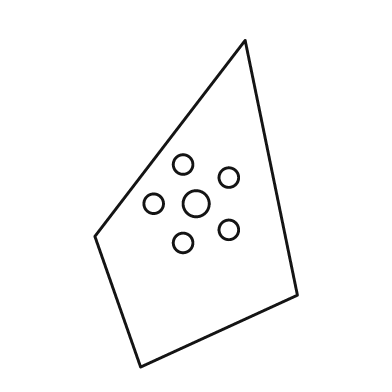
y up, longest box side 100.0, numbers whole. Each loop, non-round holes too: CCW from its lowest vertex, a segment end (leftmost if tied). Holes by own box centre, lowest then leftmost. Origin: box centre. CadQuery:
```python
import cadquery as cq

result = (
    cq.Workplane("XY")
    .moveTo(-17.0, -50.0)
    .lineTo(31.0, -28.0)
    .lineTo(15.0, 50.0)
    .lineTo(-31.0, -10.0)
    .close()
    .moveTo(-4.0, -12.0)
    .circle(3.0)
    .moveTo(10.0, -8.0)
    .circle(3.0)
    .moveTo(-13.0, 0.0)
    .circle(3.0)
    .moveTo(0.0, 0.0)
    .circle(4.0)
    .moveTo(10.0, 8.0)
    .circle(3.0)
    .moveTo(-4.0, 12.0)
    .circle(3.0)
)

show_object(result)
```